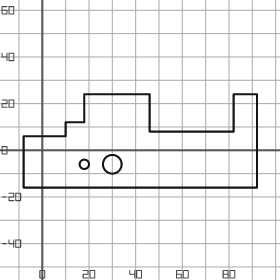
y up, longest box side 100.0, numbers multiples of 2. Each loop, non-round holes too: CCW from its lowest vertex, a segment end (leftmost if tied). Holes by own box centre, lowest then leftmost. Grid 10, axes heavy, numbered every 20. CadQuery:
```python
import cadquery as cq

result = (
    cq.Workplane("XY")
    .moveTo(-8.0, -16.0)
    .lineTo(92.0, -16.0)
    .lineTo(92.0, 24.0)
    .lineTo(82.0, 24.0)
    .lineTo(82.0, 8.0)
    .lineTo(46.0, 8.0)
    .lineTo(46.0, 24.0)
    .lineTo(18.0, 24.0)
    .lineTo(18.0, 12.0)
    .lineTo(10.0, 12.0)
    .lineTo(10.0, 6.0)
    .lineTo(-8.0, 6.0)
    .close()
    .moveTo(18.0, -6.0)
    .circle(2.0)
    .moveTo(30.0, -6.0)
    .circle(4.0)
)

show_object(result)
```